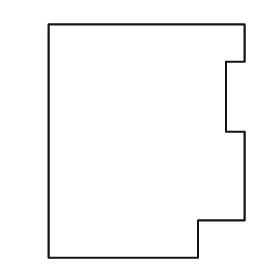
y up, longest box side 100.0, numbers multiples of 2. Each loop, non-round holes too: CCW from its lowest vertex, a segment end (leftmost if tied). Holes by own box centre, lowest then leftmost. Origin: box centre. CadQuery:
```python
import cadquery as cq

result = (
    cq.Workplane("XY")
    .moveTo(-42.0, -50.0)
    .lineTo(22.0, -50.0)
    .lineTo(22.0, -34.0)
    .lineTo(42.0, -34.0)
    .lineTo(42.0, 4.0)
    .lineTo(34.0, 4.0)
    .lineTo(34.0, 34.0)
    .lineTo(42.0, 34.0)
    .lineTo(42.0, 50.0)
    .lineTo(-42.0, 50.0)
    .close()
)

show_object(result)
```